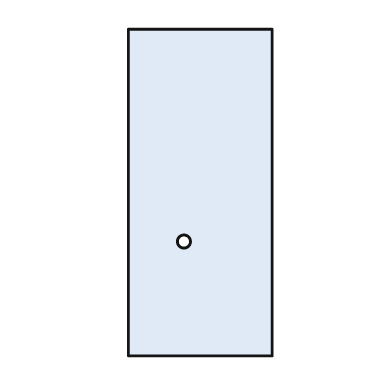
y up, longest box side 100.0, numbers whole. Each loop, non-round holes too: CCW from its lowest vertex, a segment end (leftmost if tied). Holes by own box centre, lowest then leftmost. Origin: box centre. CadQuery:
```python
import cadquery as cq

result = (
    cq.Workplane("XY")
    .moveTo(-22.0, -50.0)
    .lineTo(22.0, -50.0)
    .lineTo(22.0, 50.0)
    .lineTo(-22.0, 50.0)
    .close()
    .moveTo(-5.0, -15.0)
    .circle(2.0)
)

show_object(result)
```